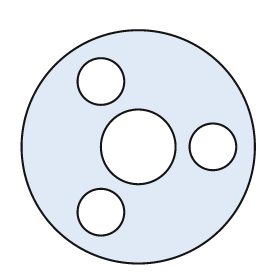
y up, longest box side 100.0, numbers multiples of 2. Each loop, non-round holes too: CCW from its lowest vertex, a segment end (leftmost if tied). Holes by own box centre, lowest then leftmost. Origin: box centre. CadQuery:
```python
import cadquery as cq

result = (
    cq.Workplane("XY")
    .moveTo(0.0, 0.0)
    .circle(50.0)
    .moveTo(-16.0, -28.0)
    .circle(10.0)
    .moveTo(0.0, 0.0)
    .circle(16.0)
    .moveTo(32.0, 0.0)
    .circle(10.0)
    .moveTo(-16.0, 28.0)
    .circle(10.0)
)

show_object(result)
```